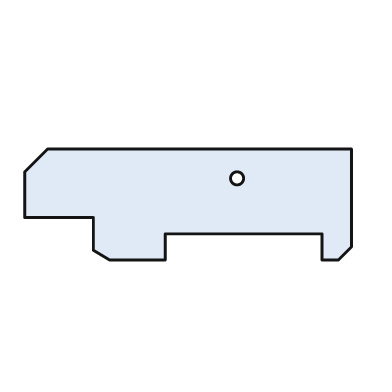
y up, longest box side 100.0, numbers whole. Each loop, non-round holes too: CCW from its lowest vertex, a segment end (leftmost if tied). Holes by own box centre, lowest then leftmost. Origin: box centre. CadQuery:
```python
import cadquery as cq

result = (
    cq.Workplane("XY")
    .moveTo(-24.0, -17.0)
    .lineTo(-7.0, -17.0)
    .lineTo(-7.0, -9.0)
    .lineTo(41.0, -9.0)
    .lineTo(41.0, -17.0)
    .lineTo(46.0, -17.0)
    .lineTo(50.0, -13.0)
    .lineTo(50.0, 17.0)
    .lineTo(-43.0, 17.0)
    .lineTo(-50.0, 10.0)
    .lineTo(-50.0, -4.0)
    .lineTo(-29.0, -4.0)
    .lineTo(-29.0, -14.0)
    .close()
    .moveTo(15.0, 8.0)
    .circle(2.0)
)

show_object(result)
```